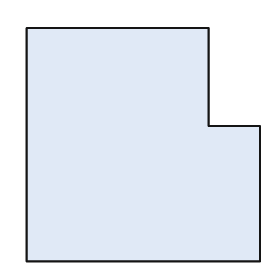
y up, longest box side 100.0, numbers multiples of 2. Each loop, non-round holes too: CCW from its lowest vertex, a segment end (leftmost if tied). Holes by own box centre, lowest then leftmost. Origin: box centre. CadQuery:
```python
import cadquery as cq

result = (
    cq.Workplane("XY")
    .moveTo(-50.0, -50.0)
    .lineTo(50.0, -50.0)
    .lineTo(50.0, 8.0)
    .lineTo(28.0, 8.0)
    .lineTo(28.0, 50.0)
    .lineTo(-50.0, 50.0)
    .close()
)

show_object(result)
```